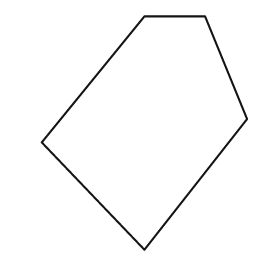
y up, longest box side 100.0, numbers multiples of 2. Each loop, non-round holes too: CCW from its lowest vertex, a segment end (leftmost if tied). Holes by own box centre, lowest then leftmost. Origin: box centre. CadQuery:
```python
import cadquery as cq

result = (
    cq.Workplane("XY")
    .moveTo(0.0, -50.0)
    .lineTo(44.0, 6.0)
    .lineTo(26.0, 50.0)
    .lineTo(0.0, 50.0)
    .lineTo(-44.0, -4.0)
    .close()
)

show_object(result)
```